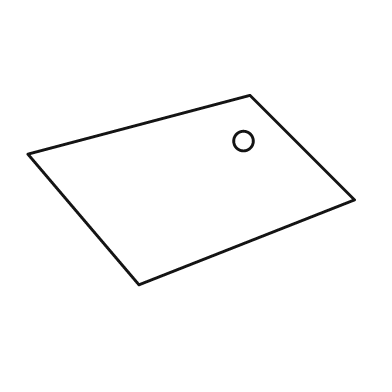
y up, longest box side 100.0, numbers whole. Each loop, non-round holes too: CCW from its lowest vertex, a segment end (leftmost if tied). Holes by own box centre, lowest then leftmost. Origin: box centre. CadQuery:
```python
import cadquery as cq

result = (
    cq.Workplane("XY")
    .moveTo(-16.0, -29.0)
    .lineTo(50.0, -3.0)
    .lineTo(18.0, 29.0)
    .lineTo(-50.0, 11.0)
    .close()
    .moveTo(16.0, 15.0)
    .circle(3.0)
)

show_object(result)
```